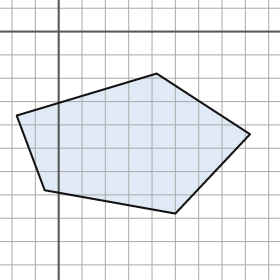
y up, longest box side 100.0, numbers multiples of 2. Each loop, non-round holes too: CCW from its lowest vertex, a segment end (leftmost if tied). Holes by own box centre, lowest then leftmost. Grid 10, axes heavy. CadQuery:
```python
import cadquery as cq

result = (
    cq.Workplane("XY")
    .moveTo(50.0, -78.0)
    .lineTo(82.0, -44.0)
    .lineTo(42.0, -18.0)
    .lineTo(-18.0, -36.0)
    .lineTo(-6.0, -68.0)
    .close()
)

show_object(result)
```